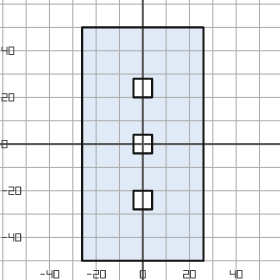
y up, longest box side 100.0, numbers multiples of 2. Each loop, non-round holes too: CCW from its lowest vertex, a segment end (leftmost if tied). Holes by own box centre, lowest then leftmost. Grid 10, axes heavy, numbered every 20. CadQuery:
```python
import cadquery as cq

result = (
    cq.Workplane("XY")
    .moveTo(-26.0, -50.0)
    .lineTo(26.0, -50.0)
    .lineTo(26.0, 50.0)
    .lineTo(-26.0, 50.0)
    .close()
    .moveTo(-4.0, -28.0)
    .lineTo(4.0, -28.0)
    .lineTo(4.0, -20.0)
    .lineTo(-4.0, -20.0)
    .close()
    .moveTo(-4.0, -4.0)
    .lineTo(4.0, -4.0)
    .lineTo(4.0, 4.0)
    .lineTo(-4.0, 4.0)
    .close()
    .moveTo(-4.0, 20.0)
    .lineTo(4.0, 20.0)
    .lineTo(4.0, 28.0)
    .lineTo(-4.0, 28.0)
    .close()
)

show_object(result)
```